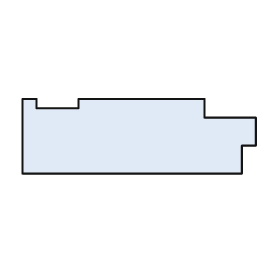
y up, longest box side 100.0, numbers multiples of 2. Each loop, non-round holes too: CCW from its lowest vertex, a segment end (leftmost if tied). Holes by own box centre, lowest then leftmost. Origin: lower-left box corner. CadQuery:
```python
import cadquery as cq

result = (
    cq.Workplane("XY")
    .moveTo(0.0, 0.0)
    .lineTo(94.0, 0.0)
    .lineTo(94.0, 12.0)
    .lineTo(100.0, 12.0)
    .lineTo(100.0, 24.0)
    .lineTo(78.0, 24.0)
    .lineTo(78.0, 32.0)
    .lineTo(24.0, 32.0)
    .lineTo(24.0, 28.0)
    .lineTo(6.0, 28.0)
    .lineTo(6.0, 32.0)
    .lineTo(0.0, 32.0)
    .close()
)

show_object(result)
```